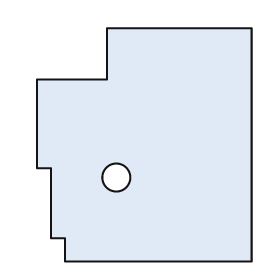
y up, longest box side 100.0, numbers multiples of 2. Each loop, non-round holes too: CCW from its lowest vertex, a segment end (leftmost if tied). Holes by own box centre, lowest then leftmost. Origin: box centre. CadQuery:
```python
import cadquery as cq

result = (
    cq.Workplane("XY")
    .moveTo(-34.0, -50.0)
    .lineTo(46.0, -50.0)
    .lineTo(46.0, 50.0)
    .lineTo(-16.0, 50.0)
    .lineTo(-16.0, 28.0)
    .lineTo(-46.0, 28.0)
    .lineTo(-46.0, -10.0)
    .lineTo(-40.0, -10.0)
    .lineTo(-40.0, -40.0)
    .lineTo(-34.0, -40.0)
    .close()
    .moveTo(-12.0, -14.0)
    .circle(6.0)
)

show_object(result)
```